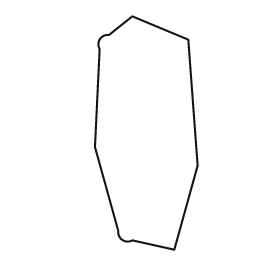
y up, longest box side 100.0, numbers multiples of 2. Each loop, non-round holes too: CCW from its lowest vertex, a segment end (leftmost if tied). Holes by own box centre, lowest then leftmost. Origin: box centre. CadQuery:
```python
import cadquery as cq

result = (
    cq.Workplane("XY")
    .moveTo(12.0, -50.0)
    .lineTo(22.0, -14.0)
    .lineTo(18.0, 40.0)
    .lineTo(-6.0, 50.0)
    .lineTo(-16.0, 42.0)
    .threePointArc((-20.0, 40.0), (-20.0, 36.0))
    .lineTo(-22.0, -6.0)
    .lineTo(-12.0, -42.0)
    .threePointArc((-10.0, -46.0), (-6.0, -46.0))
    .close()
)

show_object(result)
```